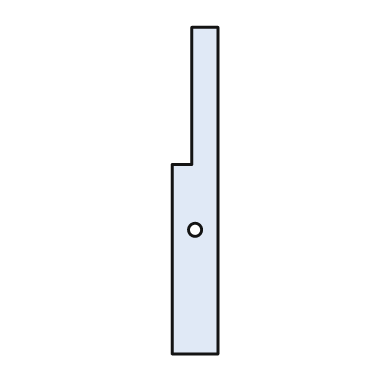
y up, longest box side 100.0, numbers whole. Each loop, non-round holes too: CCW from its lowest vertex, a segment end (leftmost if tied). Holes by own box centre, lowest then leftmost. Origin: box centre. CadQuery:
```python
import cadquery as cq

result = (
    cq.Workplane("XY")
    .moveTo(-7.0, -50.0)
    .lineTo(7.0, -50.0)
    .lineTo(7.0, 50.0)
    .lineTo(-1.0, 50.0)
    .lineTo(-1.0, 8.0)
    .lineTo(-7.0, 8.0)
    .close()
    .moveTo(0.0, -12.0)
    .circle(2.0)
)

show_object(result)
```